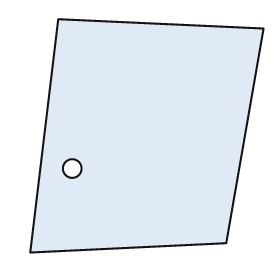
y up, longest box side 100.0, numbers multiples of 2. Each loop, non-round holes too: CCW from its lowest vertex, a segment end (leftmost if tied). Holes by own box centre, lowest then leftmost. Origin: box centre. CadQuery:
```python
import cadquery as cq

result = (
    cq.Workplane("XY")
    .moveTo(-50.0, -50.0)
    .lineTo(34.0, -46.0)
    .lineTo(50.0, 46.0)
    .lineTo(-38.0, 50.0)
    .close()
    .moveTo(-32.0, -14.0)
    .circle(4.0)
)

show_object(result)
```